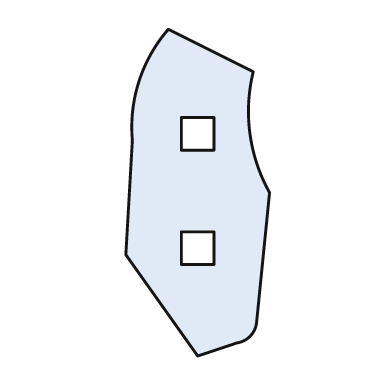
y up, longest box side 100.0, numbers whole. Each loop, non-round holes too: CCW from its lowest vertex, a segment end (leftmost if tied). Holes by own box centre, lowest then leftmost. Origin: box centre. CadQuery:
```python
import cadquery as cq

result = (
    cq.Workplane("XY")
    .moveTo(0.0, -50.0)
    .lineTo(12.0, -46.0)
    .threePointArc((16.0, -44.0), (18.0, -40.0))
    .lineTo(22.0, 0.0)
    .threePointArc((16.0, 18.0), (17.0, 37.0))
    .lineTo(-9.0, 50.0)
    .threePointArc((-18.0, 34.0), (-20.0, 16.0))
    .lineTo(-22.0, -19.0)
    .close()
    .moveTo(-5.0, -22.0)
    .lineTo(5.0, -22.0)
    .lineTo(5.0, -12.0)
    .lineTo(-5.0, -12.0)
    .close()
    .moveTo(-5.0, 13.0)
    .lineTo(5.0, 13.0)
    .lineTo(5.0, 23.0)
    .lineTo(-5.0, 23.0)
    .close()
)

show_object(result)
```